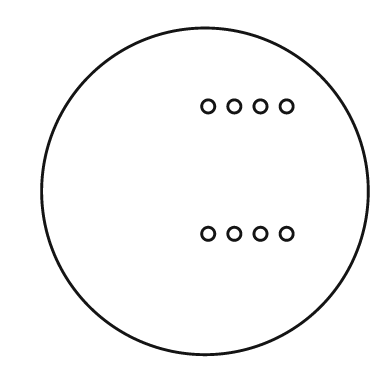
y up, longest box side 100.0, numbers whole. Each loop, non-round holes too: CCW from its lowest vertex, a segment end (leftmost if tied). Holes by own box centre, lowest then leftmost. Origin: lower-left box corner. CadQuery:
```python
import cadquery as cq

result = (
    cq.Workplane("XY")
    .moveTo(50.0, 50.0)
    .circle(50.0)
    .moveTo(51.0, 37.0)
    .circle(2.0)
    .moveTo(59.0, 37.0)
    .circle(2.0)
    .moveTo(67.0, 37.0)
    .circle(2.0)
    .moveTo(75.0, 37.0)
    .circle(2.0)
    .moveTo(51.0, 76.0)
    .circle(2.0)
    .moveTo(59.0, 76.0)
    .circle(2.0)
    .moveTo(67.0, 76.0)
    .circle(2.0)
    .moveTo(75.0, 76.0)
    .circle(2.0)
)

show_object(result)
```